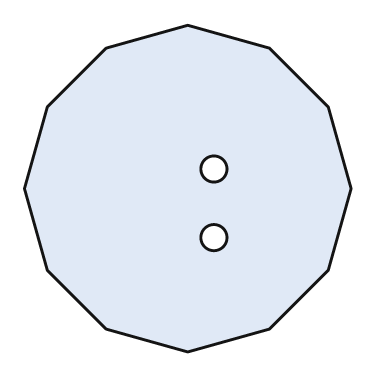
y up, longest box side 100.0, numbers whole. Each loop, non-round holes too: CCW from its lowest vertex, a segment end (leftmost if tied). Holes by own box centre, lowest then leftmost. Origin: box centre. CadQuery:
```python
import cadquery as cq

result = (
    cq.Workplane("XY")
    .moveTo(0.0, -50.0)
    .lineTo(25.0, -43.0)
    .lineTo(43.0, -25.0)
    .lineTo(50.0, 0.0)
    .lineTo(43.0, 25.0)
    .lineTo(25.0, 43.0)
    .lineTo(0.0, 50.0)
    .lineTo(-25.0, 43.0)
    .lineTo(-43.0, 25.0)
    .lineTo(-50.0, 0.0)
    .lineTo(-43.0, -25.0)
    .lineTo(-25.0, -43.0)
    .close()
    .moveTo(8.0, -15.0)
    .circle(4.0)
    .moveTo(8.0, 6.0)
    .circle(4.0)
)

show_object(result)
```